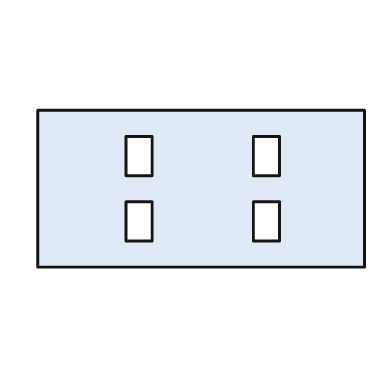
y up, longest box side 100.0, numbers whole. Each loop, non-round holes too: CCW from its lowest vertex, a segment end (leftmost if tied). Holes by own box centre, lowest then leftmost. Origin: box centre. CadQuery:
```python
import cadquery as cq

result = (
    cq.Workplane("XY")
    .moveTo(-50.0, -24.0)
    .lineTo(50.0, -24.0)
    .lineTo(50.0, 24.0)
    .lineTo(-50.0, 24.0)
    .close()
    .moveTo(-23.0, -16.0)
    .lineTo(-15.0, -16.0)
    .lineTo(-15.0, -4.0)
    .lineTo(-23.0, -4.0)
    .close()
    .moveTo(16.0, -16.0)
    .lineTo(24.0, -16.0)
    .lineTo(24.0, -4.0)
    .lineTo(16.0, -4.0)
    .close()
    .moveTo(-23.0, 4.0)
    .lineTo(-15.0, 4.0)
    .lineTo(-15.0, 16.0)
    .lineTo(-23.0, 16.0)
    .close()
    .moveTo(16.0, 4.0)
    .lineTo(24.0, 4.0)
    .lineTo(24.0, 16.0)
    .lineTo(16.0, 16.0)
    .close()
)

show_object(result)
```